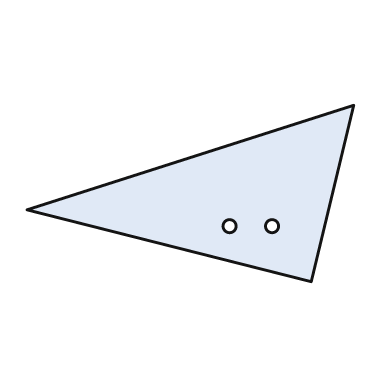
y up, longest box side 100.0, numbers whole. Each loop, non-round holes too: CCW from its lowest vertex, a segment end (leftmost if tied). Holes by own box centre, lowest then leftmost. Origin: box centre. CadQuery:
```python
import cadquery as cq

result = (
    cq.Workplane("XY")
    .moveTo(37.0, -27.0)
    .lineTo(50.0, 27.0)
    .lineTo(-50.0, -5.0)
    .close()
    .moveTo(12.0, -10.0)
    .circle(2.0)
    .moveTo(25.0, -10.0)
    .circle(2.0)
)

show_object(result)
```